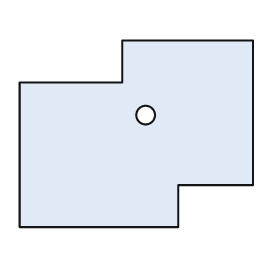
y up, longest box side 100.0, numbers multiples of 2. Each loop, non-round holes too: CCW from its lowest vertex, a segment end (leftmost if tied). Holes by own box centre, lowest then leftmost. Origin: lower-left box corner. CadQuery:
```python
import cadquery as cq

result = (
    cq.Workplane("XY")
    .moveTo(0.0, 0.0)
    .lineTo(68.0, 0.0)
    .lineTo(68.0, 18.0)
    .lineTo(100.0, 18.0)
    .lineTo(100.0, 80.0)
    .lineTo(44.0, 80.0)
    .lineTo(44.0, 62.0)
    .lineTo(0.0, 62.0)
    .close()
    .moveTo(54.0, 48.0)
    .circle(4.0)
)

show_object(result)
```